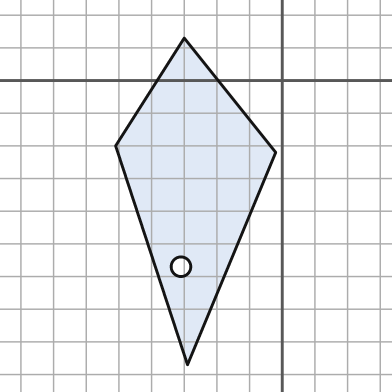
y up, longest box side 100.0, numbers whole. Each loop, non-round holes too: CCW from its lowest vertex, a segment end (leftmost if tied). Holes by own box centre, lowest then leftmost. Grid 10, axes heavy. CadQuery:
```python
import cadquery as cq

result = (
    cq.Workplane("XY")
    .moveTo(-29.0, -87.0)
    .lineTo(-2.0, -22.0)
    .lineTo(-30.0, 13.0)
    .lineTo(-51.0, -20.0)
    .close()
    .moveTo(-31.0, -57.0)
    .circle(3.0)
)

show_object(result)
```